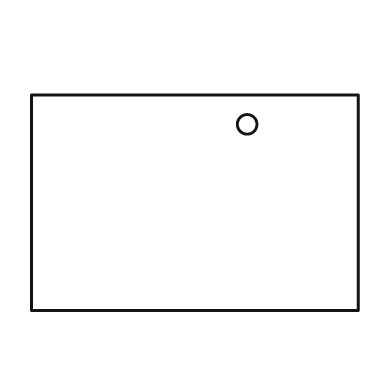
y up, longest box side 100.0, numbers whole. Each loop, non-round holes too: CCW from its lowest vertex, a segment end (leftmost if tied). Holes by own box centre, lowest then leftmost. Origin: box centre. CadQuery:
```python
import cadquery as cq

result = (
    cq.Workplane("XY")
    .moveTo(-50.0, -33.0)
    .lineTo(50.0, -33.0)
    .lineTo(50.0, 33.0)
    .lineTo(-50.0, 33.0)
    .close()
    .moveTo(16.0, 24.0)
    .circle(3.0)
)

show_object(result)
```